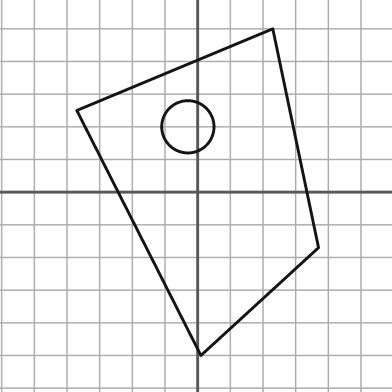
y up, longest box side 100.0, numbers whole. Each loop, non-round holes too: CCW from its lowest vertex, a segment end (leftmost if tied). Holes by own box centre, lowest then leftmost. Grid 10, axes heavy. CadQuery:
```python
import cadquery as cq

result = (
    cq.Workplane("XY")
    .moveTo(1.0, -50.0)
    .lineTo(37.0, -17.0)
    .lineTo(23.0, 50.0)
    .lineTo(-37.0, 25.0)
    .close()
    .moveTo(-3.0, 20.0)
    .circle(8.0)
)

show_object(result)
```